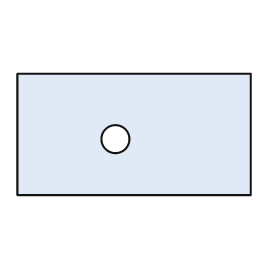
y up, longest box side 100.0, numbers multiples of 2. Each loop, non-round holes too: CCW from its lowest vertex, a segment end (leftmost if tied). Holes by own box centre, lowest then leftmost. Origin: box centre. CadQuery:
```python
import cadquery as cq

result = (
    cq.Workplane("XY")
    .moveTo(-50.0, -26.0)
    .lineTo(50.0, -26.0)
    .lineTo(50.0, 26.0)
    .lineTo(-50.0, 26.0)
    .close()
    .moveTo(-8.0, -2.0)
    .circle(6.0)
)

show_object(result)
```